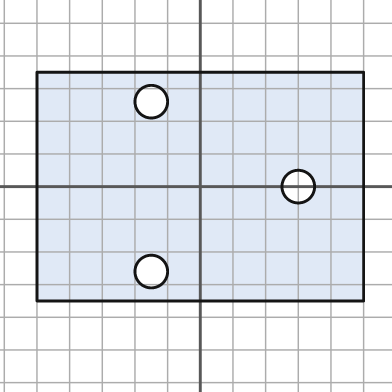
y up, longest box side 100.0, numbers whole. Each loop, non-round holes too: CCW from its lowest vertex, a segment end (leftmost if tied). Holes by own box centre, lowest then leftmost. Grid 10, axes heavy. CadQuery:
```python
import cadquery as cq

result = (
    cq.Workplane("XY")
    .moveTo(-50.0, -35.0)
    .lineTo(50.0, -35.0)
    .lineTo(50.0, 35.0)
    .lineTo(-50.0, 35.0)
    .close()
    .moveTo(-15.0, -26.0)
    .circle(5.0)
    .moveTo(30.0, 0.0)
    .circle(5.0)
    .moveTo(-15.0, 26.0)
    .circle(5.0)
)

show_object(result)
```